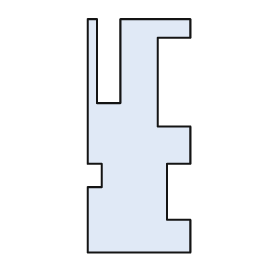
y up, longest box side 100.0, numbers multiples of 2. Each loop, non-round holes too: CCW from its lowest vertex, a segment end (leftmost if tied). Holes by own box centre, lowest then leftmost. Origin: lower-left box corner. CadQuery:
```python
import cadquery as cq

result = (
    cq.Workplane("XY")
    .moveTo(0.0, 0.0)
    .lineTo(44.0, 0.0)
    .lineTo(44.0, 14.0)
    .lineTo(34.0, 14.0)
    .lineTo(34.0, 38.0)
    .lineTo(44.0, 38.0)
    .lineTo(44.0, 54.0)
    .lineTo(30.0, 54.0)
    .lineTo(30.0, 92.0)
    .lineTo(44.0, 92.0)
    .lineTo(44.0, 100.0)
    .lineTo(14.0, 100.0)
    .lineTo(14.0, 64.0)
    .lineTo(4.0, 64.0)
    .lineTo(4.0, 100.0)
    .lineTo(0.0, 100.0)
    .lineTo(0.0, 38.0)
    .lineTo(6.0, 38.0)
    .lineTo(6.0, 28.0)
    .lineTo(0.0, 28.0)
    .close()
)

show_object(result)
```